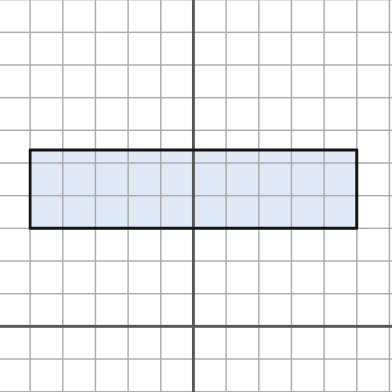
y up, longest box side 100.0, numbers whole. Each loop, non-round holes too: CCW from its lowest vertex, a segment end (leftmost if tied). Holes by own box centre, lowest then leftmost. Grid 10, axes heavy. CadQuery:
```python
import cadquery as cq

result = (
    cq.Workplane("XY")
    .moveTo(-50.0, 30.0)
    .lineTo(50.0, 30.0)
    .lineTo(50.0, 54.0)
    .lineTo(-50.0, 54.0)
    .close()
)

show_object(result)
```